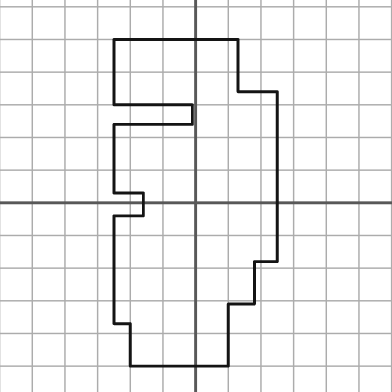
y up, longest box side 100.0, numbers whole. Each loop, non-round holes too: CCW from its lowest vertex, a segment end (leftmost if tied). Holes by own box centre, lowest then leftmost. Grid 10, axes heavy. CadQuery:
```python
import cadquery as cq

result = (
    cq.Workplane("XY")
    .moveTo(-20.0, -50.0)
    .lineTo(10.0, -50.0)
    .lineTo(10.0, -31.0)
    .lineTo(18.0, -31.0)
    .lineTo(18.0, -18.0)
    .lineTo(25.0, -18.0)
    .lineTo(25.0, 34.0)
    .lineTo(13.0, 34.0)
    .lineTo(13.0, 50.0)
    .lineTo(-25.0, 50.0)
    .lineTo(-25.0, 30.0)
    .lineTo(-1.0, 30.0)
    .lineTo(-1.0, 24.0)
    .lineTo(-25.0, 24.0)
    .lineTo(-25.0, 3.0)
    .lineTo(-16.0, 3.0)
    .lineTo(-16.0, -4.0)
    .lineTo(-25.0, -4.0)
    .lineTo(-25.0, -37.0)
    .lineTo(-20.0, -37.0)
    .close()
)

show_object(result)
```